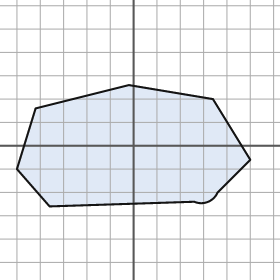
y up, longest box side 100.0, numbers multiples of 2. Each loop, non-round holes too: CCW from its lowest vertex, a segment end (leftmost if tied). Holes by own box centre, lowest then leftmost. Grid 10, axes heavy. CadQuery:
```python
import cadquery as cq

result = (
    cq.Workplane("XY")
    .moveTo(-36.0, -26.0)
    .lineTo(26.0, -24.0)
    .threePointArc((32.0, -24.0), (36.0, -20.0))
    .lineTo(50.0, -6.0)
    .lineTo(34.0, 20.0)
    .lineTo(-2.0, 26.0)
    .lineTo(-42.0, 16.0)
    .lineTo(-50.0, -10.0)
    .close()
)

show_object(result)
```